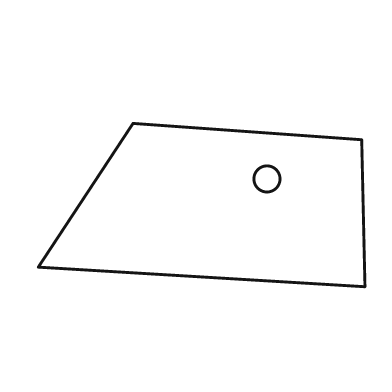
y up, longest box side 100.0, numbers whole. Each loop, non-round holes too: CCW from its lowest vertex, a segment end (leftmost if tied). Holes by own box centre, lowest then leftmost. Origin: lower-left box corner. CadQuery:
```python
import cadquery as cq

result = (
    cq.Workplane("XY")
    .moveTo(100.0, 0.0)
    .lineTo(99.0, 45.0)
    .lineTo(29.0, 50.0)
    .lineTo(0.0, 6.0)
    .close()
    .moveTo(70.0, 33.0)
    .circle(4.0)
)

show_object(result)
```